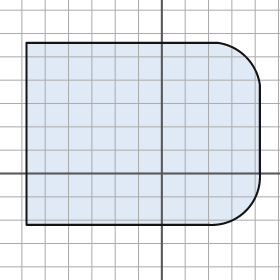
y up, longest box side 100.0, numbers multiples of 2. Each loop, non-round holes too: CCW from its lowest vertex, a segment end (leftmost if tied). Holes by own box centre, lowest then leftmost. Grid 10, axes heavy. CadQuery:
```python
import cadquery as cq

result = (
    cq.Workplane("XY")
    .moveTo(-58.0, -22.0)
    .lineTo(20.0, -22.0)
    .threePointArc((36.0, -16.0), (42.0, 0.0))
    .lineTo(42.0, 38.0)
    .threePointArc((36.0, 50.0), (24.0, 56.0))
    .lineTo(-58.0, 56.0)
    .close()
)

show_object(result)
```